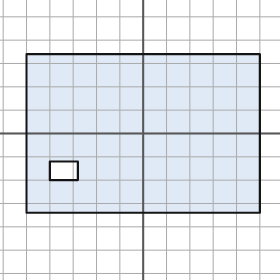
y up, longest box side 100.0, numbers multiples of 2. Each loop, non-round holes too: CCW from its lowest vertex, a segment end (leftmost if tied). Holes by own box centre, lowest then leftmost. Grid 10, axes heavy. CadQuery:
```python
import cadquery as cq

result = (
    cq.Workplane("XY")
    .moveTo(-50.0, -34.0)
    .lineTo(50.0, -34.0)
    .lineTo(50.0, 34.0)
    .lineTo(-50.0, 34.0)
    .close()
    .moveTo(-40.0, -20.0)
    .lineTo(-28.0, -20.0)
    .lineTo(-28.0, -12.0)
    .lineTo(-40.0, -12.0)
    .close()
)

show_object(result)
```